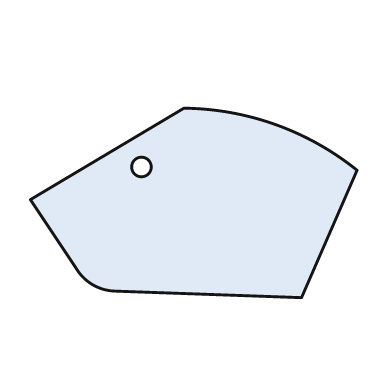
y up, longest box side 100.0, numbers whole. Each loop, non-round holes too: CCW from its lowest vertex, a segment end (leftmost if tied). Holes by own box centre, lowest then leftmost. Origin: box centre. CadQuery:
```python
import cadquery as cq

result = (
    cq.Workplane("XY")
    .moveTo(33.0, -29.0)
    .lineTo(50.0, 10.0)
    .threePointArc((25.0, 24.0), (-3.0, 29.0))
    .lineTo(-50.0, 1.0)
    .lineTo(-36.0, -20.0)
    .threePointArc((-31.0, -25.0), (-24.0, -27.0))
    .close()
    .moveTo(-16.0, 11.0)
    .circle(3.0)
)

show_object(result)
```